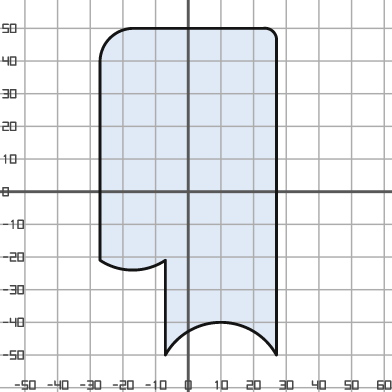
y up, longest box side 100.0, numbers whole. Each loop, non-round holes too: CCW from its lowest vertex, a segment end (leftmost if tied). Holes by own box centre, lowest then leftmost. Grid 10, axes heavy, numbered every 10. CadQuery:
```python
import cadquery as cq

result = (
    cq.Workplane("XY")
    .moveTo(-7.0, -50.0)
    .threePointArc((10.0, -40.0), (27.0, -50.0))
    .lineTo(27.0, 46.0)
    .threePointArc((26.0, 49.0), (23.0, 50.0))
    .lineTo(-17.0, 50.0)
    .threePointArc((-24.0, 47.0), (-27.0, 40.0))
    .lineTo(-27.0, -21.0)
    .threePointArc((-17.0, -24.0), (-7.0, -21.0))
    .close()
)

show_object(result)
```